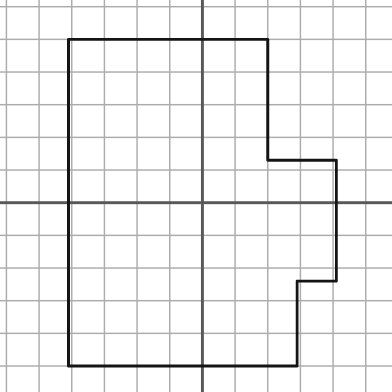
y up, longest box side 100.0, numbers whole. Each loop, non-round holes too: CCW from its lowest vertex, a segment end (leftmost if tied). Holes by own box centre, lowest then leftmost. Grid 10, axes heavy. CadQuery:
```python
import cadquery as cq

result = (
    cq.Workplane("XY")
    .moveTo(-41.0, -50.0)
    .lineTo(29.0, -50.0)
    .lineTo(29.0, -24.0)
    .lineTo(41.0, -24.0)
    .lineTo(41.0, 13.0)
    .lineTo(20.0, 13.0)
    .lineTo(20.0, 50.0)
    .lineTo(-41.0, 50.0)
    .close()
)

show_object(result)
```